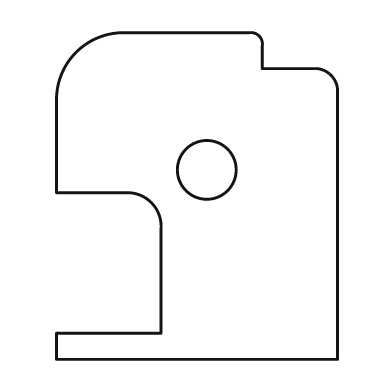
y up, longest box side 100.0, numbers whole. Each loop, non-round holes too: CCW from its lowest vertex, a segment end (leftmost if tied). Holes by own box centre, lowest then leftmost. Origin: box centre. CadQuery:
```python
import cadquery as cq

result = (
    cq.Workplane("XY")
    .moveTo(-43.0, -50.0)
    .lineTo(43.0, -50.0)
    .lineTo(43.0, 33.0)
    .threePointArc((41.0, 37.0), (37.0, 39.0))
    .lineTo(20.0, 39.0)
    .lineTo(20.0, 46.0)
    .threePointArc((19.0, 49.0), (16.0, 50.0))
    .lineTo(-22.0, 50.0)
    .threePointArc((-37.0, 44.0), (-43.0, 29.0))
    .lineTo(-43.0, 1.0)
    .lineTo(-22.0, 1.0)
    .threePointArc((-14.0, -2.0), (-11.0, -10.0))
    .lineTo(-11.0, -42.0)
    .lineTo(-43.0, -42.0)
    .close()
    .moveTo(3.0, 8.0)
    .circle(9.0)
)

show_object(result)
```